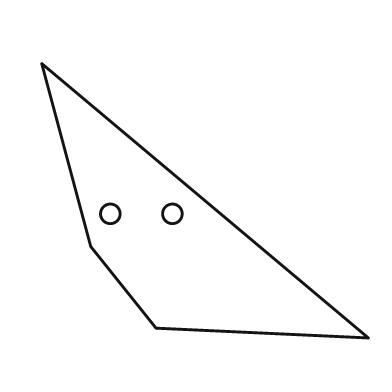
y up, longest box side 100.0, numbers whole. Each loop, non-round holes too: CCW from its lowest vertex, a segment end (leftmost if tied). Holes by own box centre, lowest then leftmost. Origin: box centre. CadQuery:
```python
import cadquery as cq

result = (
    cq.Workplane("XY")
    .moveTo(50.0, -42.0)
    .lineTo(-50.0, 42.0)
    .lineTo(-35.0, -14.0)
    .lineTo(-15.0, -39.0)
    .close()
    .moveTo(-29.0, -4.0)
    .circle(3.0)
    .moveTo(-10.0, -4.0)
    .circle(3.0)
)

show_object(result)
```